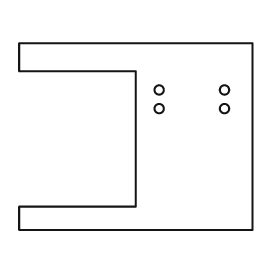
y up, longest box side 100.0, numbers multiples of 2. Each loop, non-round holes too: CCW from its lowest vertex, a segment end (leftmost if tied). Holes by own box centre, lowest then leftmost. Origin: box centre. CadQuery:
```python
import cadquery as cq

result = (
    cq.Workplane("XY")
    .moveTo(-50.0, -40.0)
    .lineTo(50.0, -40.0)
    .lineTo(50.0, 40.0)
    .lineTo(-50.0, 40.0)
    .lineTo(-50.0, 28.0)
    .lineTo(0.0, 28.0)
    .lineTo(0.0, -30.0)
    .lineTo(-50.0, -30.0)
    .close()
    .moveTo(10.0, 12.0)
    .circle(2.0)
    .moveTo(38.0, 12.0)
    .circle(2.0)
    .moveTo(10.0, 20.0)
    .circle(2.0)
    .moveTo(38.0, 20.0)
    .circle(2.0)
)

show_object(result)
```